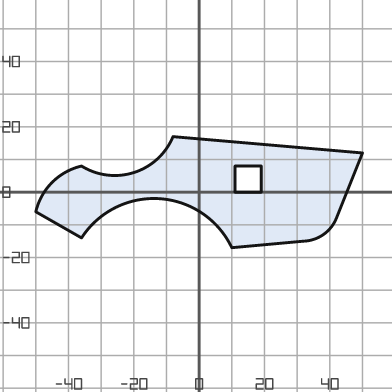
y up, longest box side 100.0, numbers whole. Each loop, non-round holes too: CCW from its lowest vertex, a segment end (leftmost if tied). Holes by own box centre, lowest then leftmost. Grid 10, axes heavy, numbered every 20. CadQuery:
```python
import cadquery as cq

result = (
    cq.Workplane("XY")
    .moveTo(10.0, -17.0)
    .lineTo(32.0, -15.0)
    .threePointArc((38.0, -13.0), (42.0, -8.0))
    .lineTo(50.0, 12.0)
    .lineTo(-8.0, 17.0)
    .threePointArc((-20.0, 6.0), (-36.0, 8.0))
    .threePointArc((-45.0, 3.0), (-50.0, -6.0))
    .lineTo(-36.0, -14.0)
    .threePointArc((-12.0, -2.0), (10.0, -17.0))
    .close()
    .moveTo(11.0, 0.0)
    .lineTo(19.0, 0.0)
    .lineTo(19.0, 8.0)
    .lineTo(11.0, 8.0)
    .close()
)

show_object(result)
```